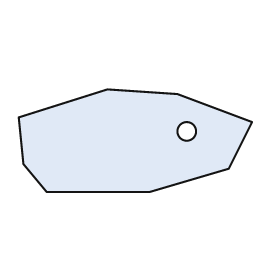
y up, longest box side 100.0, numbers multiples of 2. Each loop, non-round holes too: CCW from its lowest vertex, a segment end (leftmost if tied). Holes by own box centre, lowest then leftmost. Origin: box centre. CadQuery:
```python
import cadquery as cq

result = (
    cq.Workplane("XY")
    .moveTo(-38.0, -22.0)
    .lineTo(6.0, -22.0)
    .lineTo(40.0, -12.0)
    .lineTo(50.0, 8.0)
    .lineTo(18.0, 20.0)
    .lineTo(-12.0, 22.0)
    .lineTo(-50.0, 10.0)
    .lineTo(-48.0, -10.0)
    .close()
    .moveTo(22.0, 4.0)
    .circle(4.0)
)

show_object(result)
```